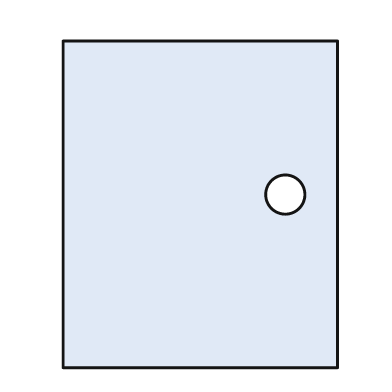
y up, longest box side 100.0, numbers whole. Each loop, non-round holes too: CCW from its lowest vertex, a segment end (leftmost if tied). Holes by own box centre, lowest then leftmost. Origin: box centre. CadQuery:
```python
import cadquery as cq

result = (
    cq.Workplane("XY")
    .moveTo(-42.0, -50.0)
    .lineTo(42.0, -50.0)
    .lineTo(42.0, 50.0)
    .lineTo(-42.0, 50.0)
    .close()
    .moveTo(26.0, 3.0)
    .circle(6.0)
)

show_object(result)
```